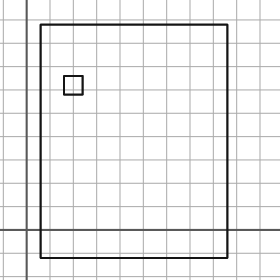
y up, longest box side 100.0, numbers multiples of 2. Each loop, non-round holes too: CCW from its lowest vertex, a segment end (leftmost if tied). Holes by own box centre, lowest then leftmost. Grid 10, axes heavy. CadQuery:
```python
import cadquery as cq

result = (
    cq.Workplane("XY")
    .moveTo(6.0, -12.0)
    .lineTo(86.0, -12.0)
    .lineTo(86.0, 88.0)
    .lineTo(6.0, 88.0)
    .close()
    .moveTo(16.0, 58.0)
    .lineTo(24.0, 58.0)
    .lineTo(24.0, 66.0)
    .lineTo(16.0, 66.0)
    .close()
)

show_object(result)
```